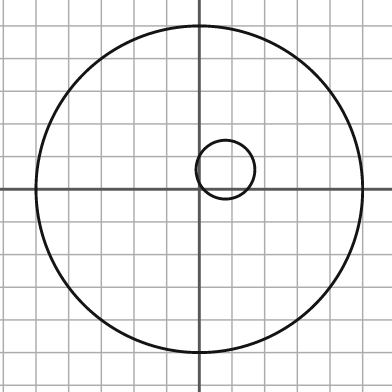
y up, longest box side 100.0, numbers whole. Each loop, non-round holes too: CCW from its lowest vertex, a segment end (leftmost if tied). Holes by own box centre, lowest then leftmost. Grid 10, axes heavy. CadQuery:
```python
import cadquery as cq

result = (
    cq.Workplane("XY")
    .moveTo(0.0, 0.0)
    .circle(50.0)
    .moveTo(8.0, 6.0)
    .circle(9.0)
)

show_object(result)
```